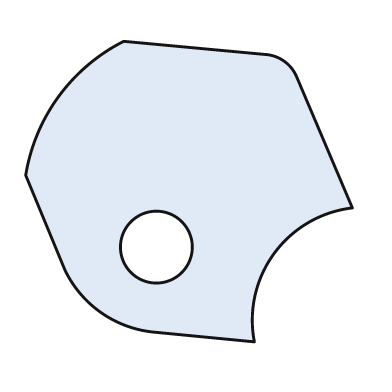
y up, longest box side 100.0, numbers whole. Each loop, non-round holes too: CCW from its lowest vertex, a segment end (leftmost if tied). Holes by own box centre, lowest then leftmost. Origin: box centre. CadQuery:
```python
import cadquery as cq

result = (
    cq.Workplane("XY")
    .moveTo(20.0, -46.0)
    .threePointArc((26.0, -19.0), (50.0, -5.0))
    .lineTo(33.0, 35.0)
    .threePointArc((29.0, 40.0), (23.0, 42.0))
    .lineTo(-20.0, 46.0)
    .threePointArc((-40.0, 29.0), (-50.0, 5.0))
    .lineTo(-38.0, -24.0)
    .threePointArc((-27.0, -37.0), (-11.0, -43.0))
    .close()
    .moveTo(-10.0, -17.0)
    .circle(11.0)
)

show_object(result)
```